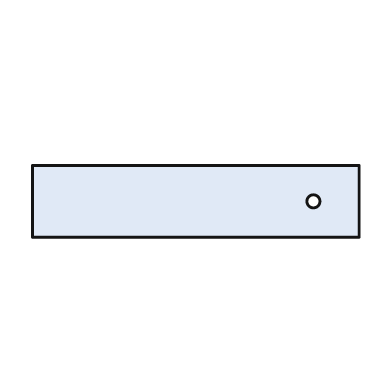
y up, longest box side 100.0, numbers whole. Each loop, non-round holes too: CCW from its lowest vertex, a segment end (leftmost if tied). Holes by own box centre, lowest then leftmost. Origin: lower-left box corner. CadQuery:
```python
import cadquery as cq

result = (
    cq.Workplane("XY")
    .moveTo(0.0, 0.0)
    .lineTo(100.0, 0.0)
    .lineTo(100.0, 22.0)
    .lineTo(0.0, 22.0)
    .close()
    .moveTo(86.0, 11.0)
    .circle(2.0)
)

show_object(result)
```